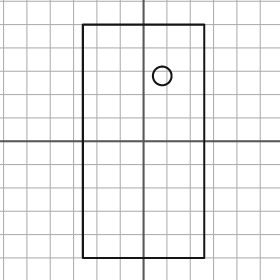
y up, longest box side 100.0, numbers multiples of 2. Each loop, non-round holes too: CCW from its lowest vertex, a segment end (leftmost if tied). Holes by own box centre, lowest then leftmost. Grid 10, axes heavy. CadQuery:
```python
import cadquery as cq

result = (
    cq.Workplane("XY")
    .moveTo(-26.0, -50.0)
    .lineTo(26.0, -50.0)
    .lineTo(26.0, 50.0)
    .lineTo(-26.0, 50.0)
    .close()
    .moveTo(8.0, 28.0)
    .circle(4.0)
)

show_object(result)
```